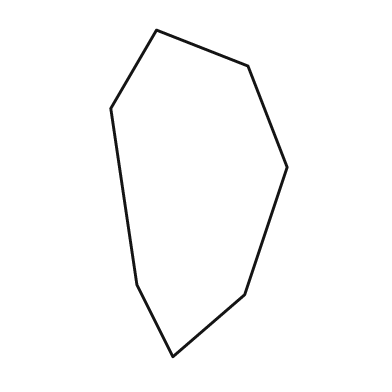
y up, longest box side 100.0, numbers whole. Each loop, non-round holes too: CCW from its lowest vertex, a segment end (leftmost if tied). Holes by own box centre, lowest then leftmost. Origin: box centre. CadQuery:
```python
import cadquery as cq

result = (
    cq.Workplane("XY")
    .moveTo(-8.0, -50.0)
    .lineTo(14.0, -31.0)
    .lineTo(27.0, 8.0)
    .lineTo(15.0, 39.0)
    .lineTo(-13.0, 50.0)
    .lineTo(-27.0, 26.0)
    .lineTo(-19.0, -28.0)
    .close()
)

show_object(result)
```